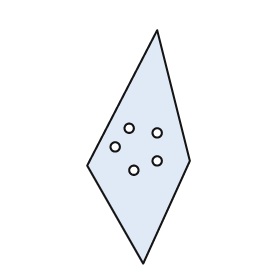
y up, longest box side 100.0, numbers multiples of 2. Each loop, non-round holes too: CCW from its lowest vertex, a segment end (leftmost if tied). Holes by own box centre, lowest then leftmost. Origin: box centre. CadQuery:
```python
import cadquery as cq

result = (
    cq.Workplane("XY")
    .moveTo(2.0, -50.0)
    .lineTo(22.0, -6.0)
    .lineTo(8.0, 50.0)
    .lineTo(-22.0, -8.0)
    .close()
    .moveTo(-2.0, -10.0)
    .circle(2.0)
    .moveTo(8.0, -6.0)
    .circle(2.0)
    .moveTo(-10.0, 0.0)
    .circle(2.0)
    .moveTo(8.0, 6.0)
    .circle(2.0)
    .moveTo(-4.0, 8.0)
    .circle(2.0)
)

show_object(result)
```